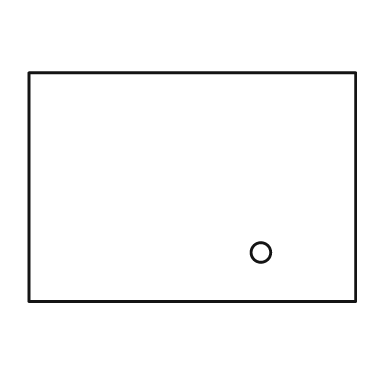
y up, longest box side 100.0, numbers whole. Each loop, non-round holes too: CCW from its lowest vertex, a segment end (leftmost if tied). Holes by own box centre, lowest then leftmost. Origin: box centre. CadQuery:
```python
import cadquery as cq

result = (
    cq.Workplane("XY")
    .moveTo(-50.0, -35.0)
    .lineTo(50.0, -35.0)
    .lineTo(50.0, 35.0)
    .lineTo(-50.0, 35.0)
    .close()
    .moveTo(21.0, -20.0)
    .circle(3.0)
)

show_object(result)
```